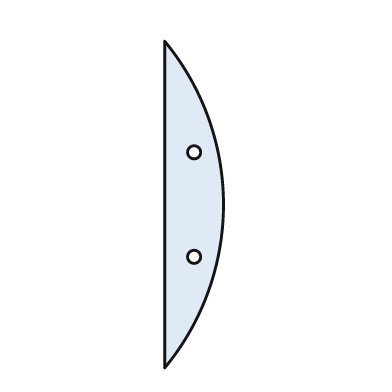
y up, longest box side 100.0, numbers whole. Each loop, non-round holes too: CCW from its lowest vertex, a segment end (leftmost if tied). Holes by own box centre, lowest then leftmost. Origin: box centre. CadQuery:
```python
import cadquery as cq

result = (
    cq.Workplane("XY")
    .moveTo(-9.0, -50.0)
    .threePointArc((9.0, 0.0), (-9.0, 50.0))
    .close()
    .moveTo(0.0, -16.0)
    .circle(2.0)
    .moveTo(0.0, 16.0)
    .circle(2.0)
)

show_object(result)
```